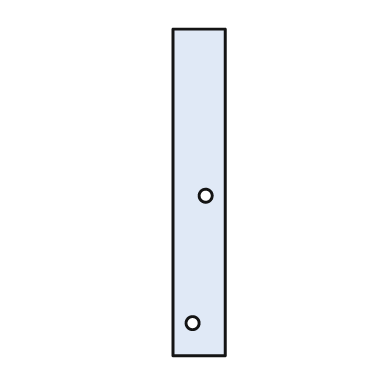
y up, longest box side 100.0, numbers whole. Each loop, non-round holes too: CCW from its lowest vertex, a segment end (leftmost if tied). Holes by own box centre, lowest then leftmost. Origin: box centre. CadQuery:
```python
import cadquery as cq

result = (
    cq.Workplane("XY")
    .moveTo(-8.0, -50.0)
    .lineTo(8.0, -50.0)
    .lineTo(8.0, 50.0)
    .lineTo(-8.0, 50.0)
    .close()
    .moveTo(-2.0, -40.0)
    .circle(2.0)
    .moveTo(2.0, -1.0)
    .circle(2.0)
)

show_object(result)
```